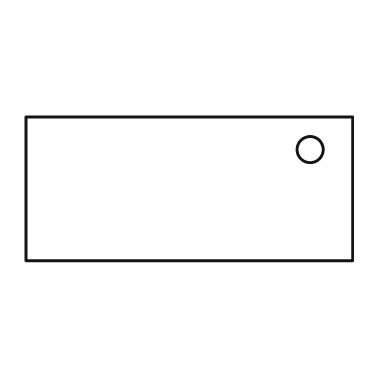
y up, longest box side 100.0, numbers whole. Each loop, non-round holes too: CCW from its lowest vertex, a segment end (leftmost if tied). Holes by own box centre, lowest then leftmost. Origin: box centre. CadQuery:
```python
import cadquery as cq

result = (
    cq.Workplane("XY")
    .moveTo(-50.0, -22.0)
    .lineTo(50.0, -22.0)
    .lineTo(50.0, 22.0)
    .lineTo(-50.0, 22.0)
    .close()
    .moveTo(37.0, 12.0)
    .circle(4.0)
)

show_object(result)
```